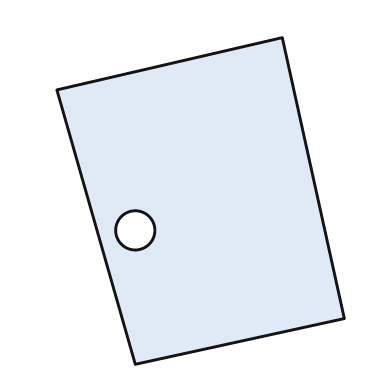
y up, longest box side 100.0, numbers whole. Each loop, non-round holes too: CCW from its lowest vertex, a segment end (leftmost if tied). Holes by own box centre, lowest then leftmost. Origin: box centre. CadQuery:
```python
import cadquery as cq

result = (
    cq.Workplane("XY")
    .moveTo(-20.0, -50.0)
    .lineTo(44.0, -36.0)
    .lineTo(25.0, 50.0)
    .lineTo(-44.0, 34.0)
    .close()
    .moveTo(-20.0, -9.0)
    .circle(6.0)
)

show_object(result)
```